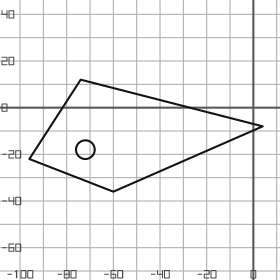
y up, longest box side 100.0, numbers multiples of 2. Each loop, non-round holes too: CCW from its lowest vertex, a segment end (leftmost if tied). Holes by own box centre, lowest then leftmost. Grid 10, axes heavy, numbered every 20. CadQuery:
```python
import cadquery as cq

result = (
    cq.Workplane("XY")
    .moveTo(-60.0, -36.0)
    .lineTo(4.0, -8.0)
    .lineTo(-74.0, 12.0)
    .lineTo(-96.0, -22.0)
    .close()
    .moveTo(-72.0, -18.0)
    .circle(4.0)
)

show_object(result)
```